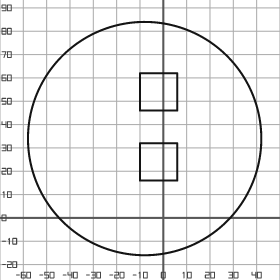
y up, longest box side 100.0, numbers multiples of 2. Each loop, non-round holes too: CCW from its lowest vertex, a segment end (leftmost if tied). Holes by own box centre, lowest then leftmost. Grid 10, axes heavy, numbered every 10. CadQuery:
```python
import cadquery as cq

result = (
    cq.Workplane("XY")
    .moveTo(-8.0, 34.0)
    .circle(50.0)
    .moveTo(-10.0, 16.0)
    .lineTo(6.0, 16.0)
    .lineTo(6.0, 32.0)
    .lineTo(-10.0, 32.0)
    .close()
    .moveTo(-10.0, 46.0)
    .lineTo(6.0, 46.0)
    .lineTo(6.0, 62.0)
    .lineTo(-10.0, 62.0)
    .close()
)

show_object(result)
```